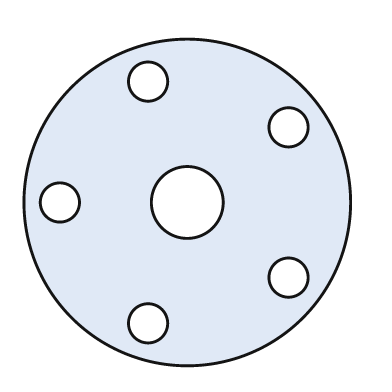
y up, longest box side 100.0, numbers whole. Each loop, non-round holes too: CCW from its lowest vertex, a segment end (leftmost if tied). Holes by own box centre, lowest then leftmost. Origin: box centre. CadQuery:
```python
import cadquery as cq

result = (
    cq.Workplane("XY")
    .moveTo(0.0, 0.0)
    .circle(50.0)
    .moveTo(-12.0, -37.0)
    .circle(6.0)
    .moveTo(31.0, -23.0)
    .circle(6.0)
    .moveTo(-39.0, 0.0)
    .circle(6.0)
    .moveTo(0.0, 0.0)
    .circle(11.0)
    .moveTo(31.0, 23.0)
    .circle(6.0)
    .moveTo(-12.0, 37.0)
    .circle(6.0)
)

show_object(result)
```